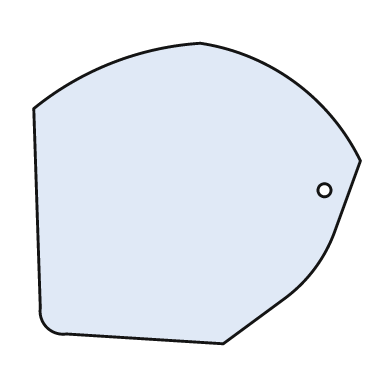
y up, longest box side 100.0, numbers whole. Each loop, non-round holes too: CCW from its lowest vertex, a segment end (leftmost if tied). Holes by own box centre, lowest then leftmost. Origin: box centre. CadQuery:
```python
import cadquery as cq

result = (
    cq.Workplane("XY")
    .moveTo(8.0, -46.0)
    .lineTo(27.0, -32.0)
    .threePointArc((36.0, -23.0), (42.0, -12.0))
    .lineTo(50.0, 10.0)
    .threePointArc((30.0, 34.0), (1.0, 46.0))
    .threePointArc((-26.0, 40.0), (-50.0, 26.0))
    .lineTo(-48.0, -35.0)
    .threePointArc((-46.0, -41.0), (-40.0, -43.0))
    .close()
    .moveTo(39.0, 1.0)
    .circle(2.0)
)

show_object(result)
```